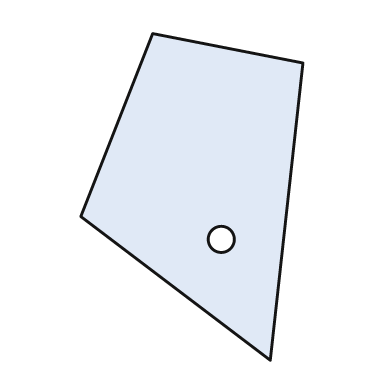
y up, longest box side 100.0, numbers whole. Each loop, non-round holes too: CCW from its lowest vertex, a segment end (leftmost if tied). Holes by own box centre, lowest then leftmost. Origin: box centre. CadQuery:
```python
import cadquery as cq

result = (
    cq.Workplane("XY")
    .moveTo(24.0, -50.0)
    .lineTo(34.0, 41.0)
    .lineTo(-12.0, 50.0)
    .lineTo(-34.0, -6.0)
    .close()
    .moveTo(9.0, -13.0)
    .circle(4.0)
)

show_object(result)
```